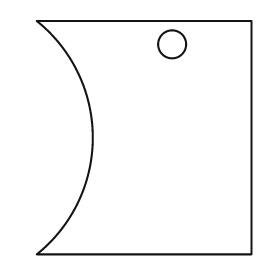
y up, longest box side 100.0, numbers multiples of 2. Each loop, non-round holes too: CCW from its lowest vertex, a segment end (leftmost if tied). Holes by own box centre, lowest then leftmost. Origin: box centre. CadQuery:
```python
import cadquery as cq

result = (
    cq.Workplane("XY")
    .moveTo(-46.0, -50.0)
    .lineTo(46.0, -50.0)
    .lineTo(46.0, 50.0)
    .lineTo(-46.0, 50.0)
    .threePointArc((-22.0, 0.0), (-46.0, -50.0))
    .close()
    .moveTo(12.0, 40.0)
    .circle(6.0)
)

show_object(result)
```